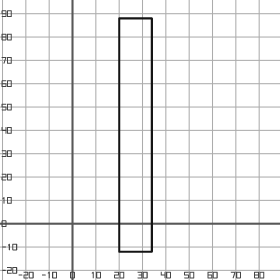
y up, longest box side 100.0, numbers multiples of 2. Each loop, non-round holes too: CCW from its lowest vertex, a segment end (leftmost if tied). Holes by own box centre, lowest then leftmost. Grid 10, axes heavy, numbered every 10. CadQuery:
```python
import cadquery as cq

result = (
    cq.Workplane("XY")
    .moveTo(20.0, -12.0)
    .lineTo(34.0, -12.0)
    .lineTo(34.0, 88.0)
    .lineTo(20.0, 88.0)
    .close()
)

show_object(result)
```